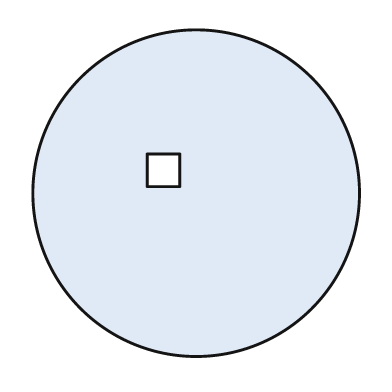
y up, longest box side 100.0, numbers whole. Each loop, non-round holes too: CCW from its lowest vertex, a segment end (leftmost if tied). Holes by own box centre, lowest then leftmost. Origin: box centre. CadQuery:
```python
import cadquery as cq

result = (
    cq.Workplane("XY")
    .moveTo(0.0, 0.0)
    .circle(50.0)
    .moveTo(-15.0, 2.0)
    .lineTo(-5.0, 2.0)
    .lineTo(-5.0, 12.0)
    .lineTo(-15.0, 12.0)
    .close()
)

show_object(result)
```